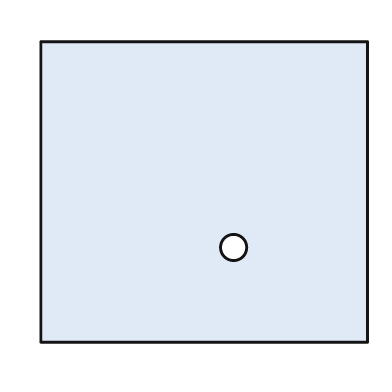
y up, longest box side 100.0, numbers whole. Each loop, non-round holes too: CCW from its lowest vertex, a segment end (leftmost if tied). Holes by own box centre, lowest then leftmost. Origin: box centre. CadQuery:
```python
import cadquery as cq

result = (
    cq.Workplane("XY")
    .moveTo(-50.0, -46.0)
    .lineTo(50.0, -46.0)
    .lineTo(50.0, 46.0)
    .lineTo(-50.0, 46.0)
    .close()
    .moveTo(9.0, -17.0)
    .circle(4.0)
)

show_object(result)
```